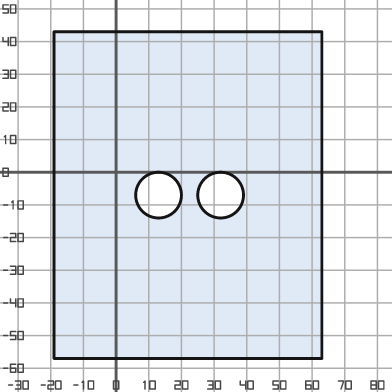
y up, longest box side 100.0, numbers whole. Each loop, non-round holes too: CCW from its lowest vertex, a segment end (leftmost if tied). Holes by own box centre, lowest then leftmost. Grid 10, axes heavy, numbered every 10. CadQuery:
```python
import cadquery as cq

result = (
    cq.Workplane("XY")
    .moveTo(-19.0, -57.0)
    .lineTo(63.0, -57.0)
    .lineTo(63.0, 43.0)
    .lineTo(-19.0, 43.0)
    .close()
    .moveTo(13.0, -7.0)
    .circle(7.0)
    .moveTo(32.0, -7.0)
    .circle(7.0)
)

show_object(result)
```